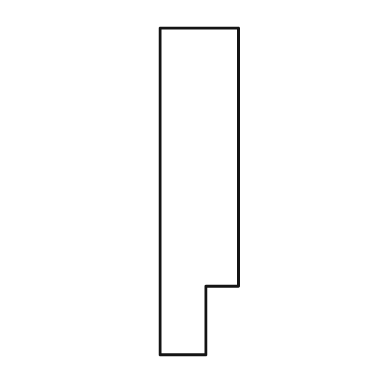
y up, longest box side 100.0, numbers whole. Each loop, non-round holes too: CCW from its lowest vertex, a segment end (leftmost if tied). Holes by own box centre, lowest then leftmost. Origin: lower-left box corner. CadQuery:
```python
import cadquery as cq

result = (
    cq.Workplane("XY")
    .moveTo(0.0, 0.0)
    .lineTo(14.0, 0.0)
    .lineTo(14.0, 21.0)
    .lineTo(24.0, 21.0)
    .lineTo(24.0, 100.0)
    .lineTo(0.0, 100.0)
    .close()
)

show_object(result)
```